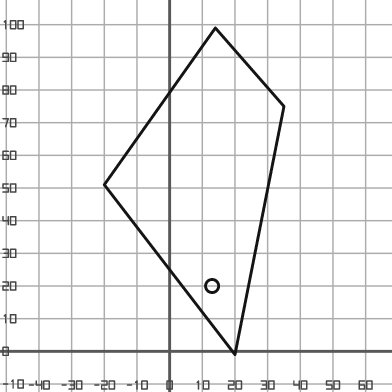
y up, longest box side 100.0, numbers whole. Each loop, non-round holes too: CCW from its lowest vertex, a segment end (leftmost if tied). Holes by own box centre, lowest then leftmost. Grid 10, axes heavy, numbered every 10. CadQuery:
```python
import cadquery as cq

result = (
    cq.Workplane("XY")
    .moveTo(20.0, -1.0)
    .lineTo(35.0, 75.0)
    .lineTo(14.0, 99.0)
    .lineTo(-20.0, 51.0)
    .close()
    .moveTo(13.0, 20.0)
    .circle(2.0)
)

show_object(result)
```